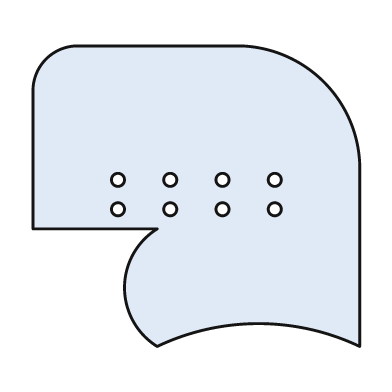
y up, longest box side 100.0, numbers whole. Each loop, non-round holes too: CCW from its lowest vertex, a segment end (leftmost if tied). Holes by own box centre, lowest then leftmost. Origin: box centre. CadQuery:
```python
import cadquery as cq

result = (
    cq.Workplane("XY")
    .moveTo(-12.0, -46.0)
    .threePointArc((19.0, -39.0), (50.0, -46.0))
    .lineTo(50.0, 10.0)
    .threePointArc((39.0, 35.0), (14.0, 46.0))
    .lineTo(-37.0, 46.0)
    .threePointArc((-46.0, 42.0), (-50.0, 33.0))
    .lineTo(-50.0, -10.0)
    .lineTo(-12.0, -10.0)
    .threePointArc((-22.0, -28.0), (-12.0, -46.0))
    .close()
    .moveTo(-24.0, -4.0)
    .circle(2.0)
    .moveTo(-8.0, -4.0)
    .circle(2.0)
    .moveTo(8.0, -4.0)
    .circle(2.0)
    .moveTo(24.0, -4.0)
    .circle(2.0)
    .moveTo(-24.0, 5.0)
    .circle(2.0)
    .moveTo(-8.0, 5.0)
    .circle(2.0)
    .moveTo(8.0, 5.0)
    .circle(2.0)
    .moveTo(24.0, 5.0)
    .circle(2.0)
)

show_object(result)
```